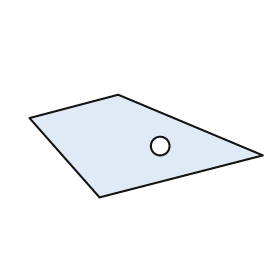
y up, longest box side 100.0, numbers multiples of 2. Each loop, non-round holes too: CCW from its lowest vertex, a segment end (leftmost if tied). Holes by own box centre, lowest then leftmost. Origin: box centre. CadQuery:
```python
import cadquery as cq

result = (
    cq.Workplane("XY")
    .moveTo(-20.0, -22.0)
    .lineTo(50.0, -4.0)
    .lineTo(-12.0, 22.0)
    .lineTo(-50.0, 12.0)
    .close()
    .moveTo(6.0, 0.0)
    .circle(4.0)
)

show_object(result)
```